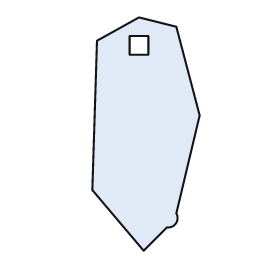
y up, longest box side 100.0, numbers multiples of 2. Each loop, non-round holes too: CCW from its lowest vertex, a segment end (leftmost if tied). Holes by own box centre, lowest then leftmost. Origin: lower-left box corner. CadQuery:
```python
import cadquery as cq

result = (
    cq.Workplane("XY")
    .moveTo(22.0, 0.0)
    .lineTo(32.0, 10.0)
    .threePointArc((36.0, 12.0), (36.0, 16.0))
    .lineTo(46.0, 58.0)
    .lineTo(36.0, 96.0)
    .lineTo(20.0, 100.0)
    .lineTo(2.0, 90.0)
    .lineTo(0.0, 26.0)
    .close()
    .moveTo(16.0, 84.0)
    .lineTo(24.0, 84.0)
    .lineTo(24.0, 92.0)
    .lineTo(16.0, 92.0)
    .close()
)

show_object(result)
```